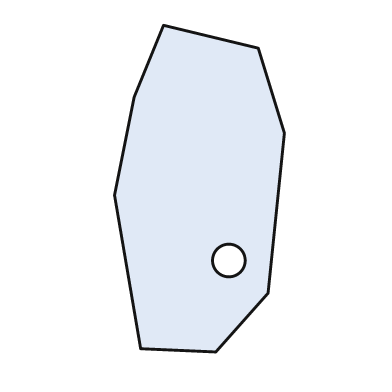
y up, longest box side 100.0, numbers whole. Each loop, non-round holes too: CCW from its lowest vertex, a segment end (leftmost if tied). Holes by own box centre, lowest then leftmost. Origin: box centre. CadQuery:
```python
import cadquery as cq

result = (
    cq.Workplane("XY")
    .moveTo(5.0, -50.0)
    .lineTo(21.0, -32.0)
    .lineTo(26.0, 17.0)
    .lineTo(18.0, 43.0)
    .lineTo(-11.0, 50.0)
    .lineTo(-20.0, 28.0)
    .lineTo(-26.0, -2.0)
    .lineTo(-18.0, -49.0)
    .close()
    .moveTo(9.0, -22.0)
    .circle(5.0)
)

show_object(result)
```